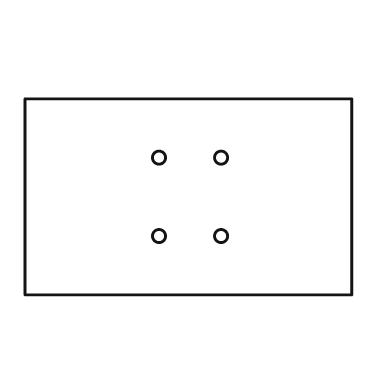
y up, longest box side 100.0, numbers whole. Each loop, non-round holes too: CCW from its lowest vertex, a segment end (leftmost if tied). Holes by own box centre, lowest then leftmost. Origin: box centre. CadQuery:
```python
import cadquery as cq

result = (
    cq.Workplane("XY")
    .moveTo(-50.0, -30.0)
    .lineTo(50.0, -30.0)
    .lineTo(50.0, 30.0)
    .lineTo(-50.0, 30.0)
    .close()
    .moveTo(-9.0, -12.0)
    .circle(2.0)
    .moveTo(10.0, -12.0)
    .circle(2.0)
    .moveTo(-9.0, 12.0)
    .circle(2.0)
    .moveTo(10.0, 12.0)
    .circle(2.0)
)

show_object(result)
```